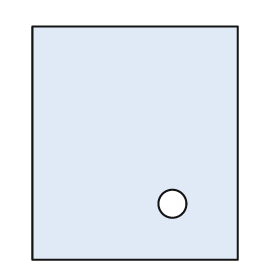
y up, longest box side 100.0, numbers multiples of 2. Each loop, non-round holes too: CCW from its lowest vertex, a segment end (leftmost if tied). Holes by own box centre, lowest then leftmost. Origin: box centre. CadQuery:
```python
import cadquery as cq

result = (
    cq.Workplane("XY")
    .moveTo(-44.0, -50.0)
    .lineTo(44.0, -50.0)
    .lineTo(44.0, 50.0)
    .lineTo(-44.0, 50.0)
    .close()
    .moveTo(16.0, -26.0)
    .circle(6.0)
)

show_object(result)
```